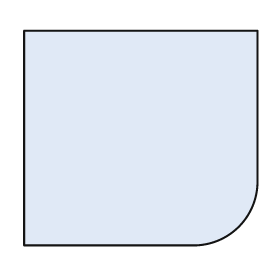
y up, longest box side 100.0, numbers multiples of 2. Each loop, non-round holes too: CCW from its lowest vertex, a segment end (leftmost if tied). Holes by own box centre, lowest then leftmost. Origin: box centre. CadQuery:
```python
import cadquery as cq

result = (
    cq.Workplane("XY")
    .moveTo(-50.0, -46.0)
    .lineTo(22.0, -46.0)
    .threePointArc((42.0, -38.0), (50.0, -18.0))
    .lineTo(50.0, 46.0)
    .lineTo(-50.0, 46.0)
    .close()
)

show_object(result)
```